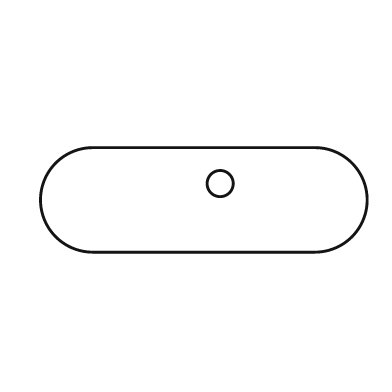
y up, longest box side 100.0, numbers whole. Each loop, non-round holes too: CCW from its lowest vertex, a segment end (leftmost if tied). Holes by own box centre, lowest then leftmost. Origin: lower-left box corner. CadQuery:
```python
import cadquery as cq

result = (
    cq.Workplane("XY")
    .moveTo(16.0, 0.0)
    .lineTo(84.0, 0.0)
    .threePointArc((100.0, 16.0), (84.0, 32.0))
    .lineTo(16.0, 32.0)
    .threePointArc((0.0, 16.0), (16.0, 0.0))
    .close()
    .moveTo(55.0, 21.0)
    .circle(4.0)
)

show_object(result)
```